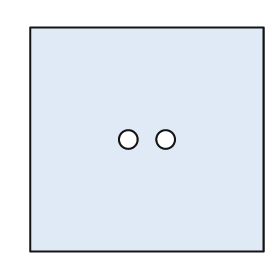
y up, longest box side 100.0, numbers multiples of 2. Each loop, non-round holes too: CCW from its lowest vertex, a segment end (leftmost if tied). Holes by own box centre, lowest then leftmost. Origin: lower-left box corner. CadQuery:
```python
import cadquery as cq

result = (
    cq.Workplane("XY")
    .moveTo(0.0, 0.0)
    .lineTo(100.0, 0.0)
    .lineTo(100.0, 96.0)
    .lineTo(0.0, 96.0)
    .close()
    .moveTo(42.0, 48.0)
    .circle(4.0)
    .moveTo(58.0, 48.0)
    .circle(4.0)
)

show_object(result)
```